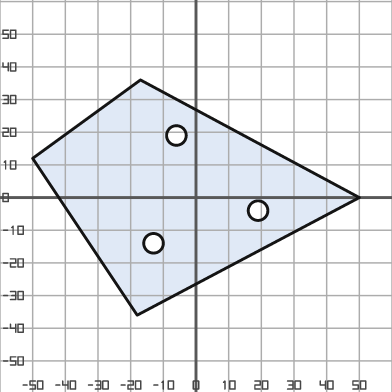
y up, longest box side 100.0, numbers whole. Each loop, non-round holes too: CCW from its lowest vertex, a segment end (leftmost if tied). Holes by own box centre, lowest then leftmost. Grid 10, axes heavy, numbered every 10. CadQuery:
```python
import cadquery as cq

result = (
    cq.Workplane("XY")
    .moveTo(-18.0, -36.0)
    .lineTo(50.0, 0.0)
    .lineTo(-17.0, 36.0)
    .lineTo(-50.0, 12.0)
    .close()
    .moveTo(-13.0, -14.0)
    .circle(3.0)
    .moveTo(19.0, -4.0)
    .circle(3.0)
    .moveTo(-6.0, 19.0)
    .circle(3.0)
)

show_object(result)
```